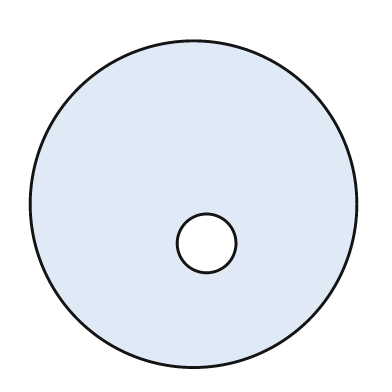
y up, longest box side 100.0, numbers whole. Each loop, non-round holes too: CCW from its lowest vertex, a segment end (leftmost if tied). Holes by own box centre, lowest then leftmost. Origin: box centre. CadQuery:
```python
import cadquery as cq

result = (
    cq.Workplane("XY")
    .moveTo(0.0, 0.0)
    .circle(50.0)
    .moveTo(4.0, -12.0)
    .circle(9.0)
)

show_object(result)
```